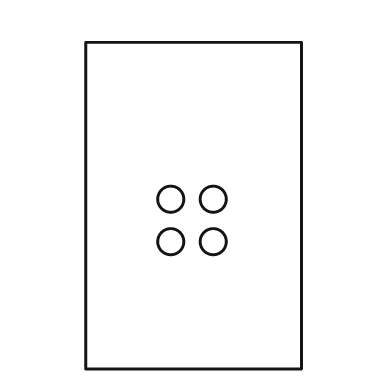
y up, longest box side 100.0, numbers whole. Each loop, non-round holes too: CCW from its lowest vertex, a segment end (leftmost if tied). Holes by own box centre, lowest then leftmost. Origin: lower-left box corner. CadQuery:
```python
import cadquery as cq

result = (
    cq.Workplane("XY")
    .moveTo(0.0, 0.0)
    .lineTo(66.0, 0.0)
    .lineTo(66.0, 100.0)
    .lineTo(0.0, 100.0)
    .close()
    .moveTo(26.0, 39.0)
    .circle(4.0)
    .moveTo(39.0, 39.0)
    .circle(4.0)
    .moveTo(26.0, 52.0)
    .circle(4.0)
    .moveTo(39.0, 52.0)
    .circle(4.0)
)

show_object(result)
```